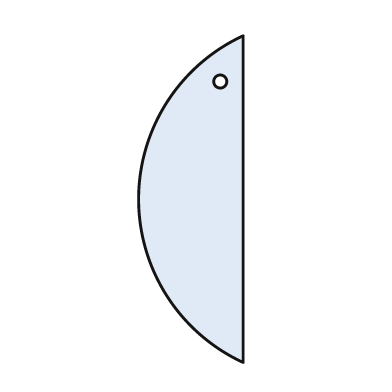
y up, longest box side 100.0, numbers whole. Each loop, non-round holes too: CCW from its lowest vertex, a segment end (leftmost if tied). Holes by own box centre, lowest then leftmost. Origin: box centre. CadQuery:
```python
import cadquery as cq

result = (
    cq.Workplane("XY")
    .moveTo(16.0, -50.0)
    .lineTo(16.0, 50.0)
    .threePointArc((-16.0, 0.0), (16.0, -50.0))
    .close()
    .moveTo(9.0, 36.0)
    .circle(2.0)
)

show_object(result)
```